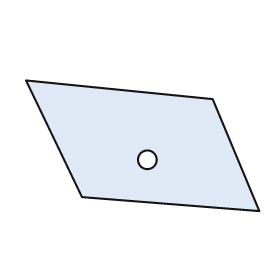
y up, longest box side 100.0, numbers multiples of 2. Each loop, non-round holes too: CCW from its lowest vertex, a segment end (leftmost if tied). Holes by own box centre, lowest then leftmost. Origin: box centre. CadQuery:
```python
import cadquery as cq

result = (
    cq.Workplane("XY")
    .moveTo(50.0, -28.0)
    .lineTo(30.0, 20.0)
    .lineTo(-50.0, 28.0)
    .lineTo(-26.0, -22.0)
    .close()
    .moveTo(2.0, -6.0)
    .circle(4.0)
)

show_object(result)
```